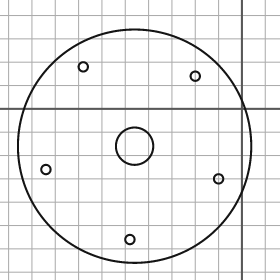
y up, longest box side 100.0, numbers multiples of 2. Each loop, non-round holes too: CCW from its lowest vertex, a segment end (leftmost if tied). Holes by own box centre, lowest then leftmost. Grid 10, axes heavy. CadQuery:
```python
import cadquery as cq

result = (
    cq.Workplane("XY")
    .moveTo(-46.0, -16.0)
    .circle(50.0)
    .moveTo(-48.0, -56.0)
    .circle(2.0)
    .moveTo(-10.0, -30.0)
    .circle(2.0)
    .moveTo(-84.0, -26.0)
    .circle(2.0)
    .moveTo(-46.0, -16.0)
    .circle(8.0)
    .moveTo(-20.0, 14.0)
    .circle(2.0)
    .moveTo(-68.0, 18.0)
    .circle(2.0)
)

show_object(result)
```